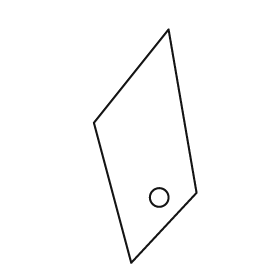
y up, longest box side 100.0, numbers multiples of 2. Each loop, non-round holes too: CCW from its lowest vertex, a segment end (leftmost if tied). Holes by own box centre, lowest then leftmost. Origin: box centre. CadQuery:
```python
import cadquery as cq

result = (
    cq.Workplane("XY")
    .moveTo(-6.0, -50.0)
    .lineTo(22.0, -20.0)
    .lineTo(10.0, 50.0)
    .lineTo(-22.0, 10.0)
    .close()
    .moveTo(6.0, -22.0)
    .circle(4.0)
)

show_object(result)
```